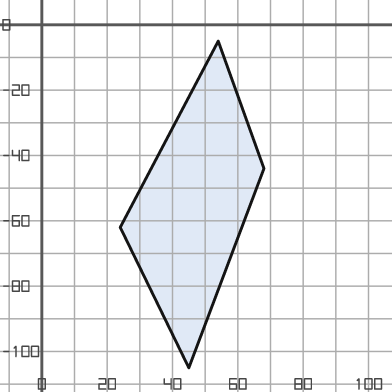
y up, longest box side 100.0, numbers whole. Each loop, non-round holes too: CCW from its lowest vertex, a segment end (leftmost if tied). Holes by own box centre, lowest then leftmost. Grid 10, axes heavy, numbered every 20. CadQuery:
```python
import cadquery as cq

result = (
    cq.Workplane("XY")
    .moveTo(45.0, -105.0)
    .lineTo(68.0, -44.0)
    .lineTo(54.0, -5.0)
    .lineTo(24.0, -62.0)
    .close()
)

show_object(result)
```